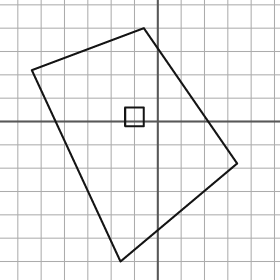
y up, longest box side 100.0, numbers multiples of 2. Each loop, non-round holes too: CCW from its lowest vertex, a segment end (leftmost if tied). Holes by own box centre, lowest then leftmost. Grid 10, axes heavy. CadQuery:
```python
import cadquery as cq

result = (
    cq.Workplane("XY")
    .moveTo(-16.0, -60.0)
    .lineTo(34.0, -18.0)
    .lineTo(-6.0, 40.0)
    .lineTo(-54.0, 22.0)
    .close()
    .moveTo(-14.0, -2.0)
    .lineTo(-6.0, -2.0)
    .lineTo(-6.0, 6.0)
    .lineTo(-14.0, 6.0)
    .close()
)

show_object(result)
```